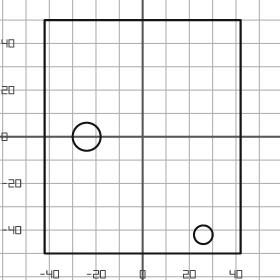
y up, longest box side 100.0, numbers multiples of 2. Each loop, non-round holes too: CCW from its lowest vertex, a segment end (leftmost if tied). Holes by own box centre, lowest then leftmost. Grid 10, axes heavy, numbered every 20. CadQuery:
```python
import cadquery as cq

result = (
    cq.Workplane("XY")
    .moveTo(-42.0, -50.0)
    .lineTo(42.0, -50.0)
    .lineTo(42.0, 50.0)
    .lineTo(-42.0, 50.0)
    .close()
    .moveTo(26.0, -42.0)
    .circle(4.0)
    .moveTo(-24.0, 0.0)
    .circle(6.0)
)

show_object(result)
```